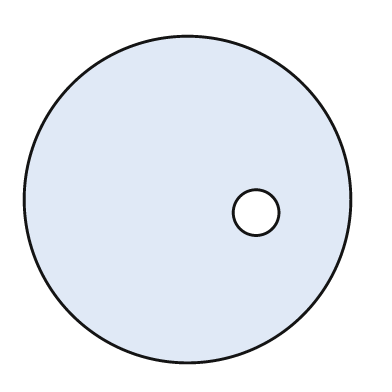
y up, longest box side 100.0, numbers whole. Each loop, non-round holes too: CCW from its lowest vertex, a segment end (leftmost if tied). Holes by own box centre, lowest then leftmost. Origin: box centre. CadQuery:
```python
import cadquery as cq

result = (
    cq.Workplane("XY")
    .moveTo(0.0, 0.0)
    .circle(50.0)
    .moveTo(21.0, -4.0)
    .circle(7.0)
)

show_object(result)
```